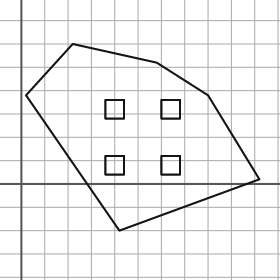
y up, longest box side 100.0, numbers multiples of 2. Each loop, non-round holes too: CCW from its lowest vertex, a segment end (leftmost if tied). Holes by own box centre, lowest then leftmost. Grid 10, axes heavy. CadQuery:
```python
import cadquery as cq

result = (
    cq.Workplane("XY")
    .moveTo(42.0, -20.0)
    .lineTo(102.0, 2.0)
    .lineTo(80.0, 38.0)
    .lineTo(58.0, 52.0)
    .lineTo(22.0, 60.0)
    .lineTo(2.0, 38.0)
    .close()
    .moveTo(36.0, 4.0)
    .lineTo(44.0, 4.0)
    .lineTo(44.0, 12.0)
    .lineTo(36.0, 12.0)
    .close()
    .moveTo(60.0, 4.0)
    .lineTo(68.0, 4.0)
    .lineTo(68.0, 12.0)
    .lineTo(60.0, 12.0)
    .close()
    .moveTo(36.0, 28.0)
    .lineTo(44.0, 28.0)
    .lineTo(44.0, 36.0)
    .lineTo(36.0, 36.0)
    .close()
    .moveTo(60.0, 28.0)
    .lineTo(68.0, 28.0)
    .lineTo(68.0, 36.0)
    .lineTo(60.0, 36.0)
    .close()
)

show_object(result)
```